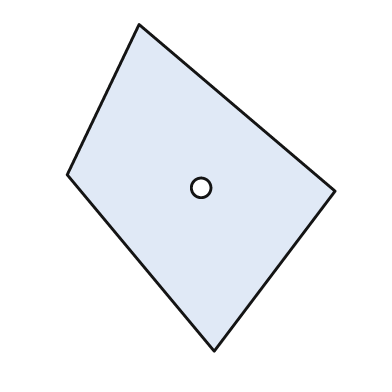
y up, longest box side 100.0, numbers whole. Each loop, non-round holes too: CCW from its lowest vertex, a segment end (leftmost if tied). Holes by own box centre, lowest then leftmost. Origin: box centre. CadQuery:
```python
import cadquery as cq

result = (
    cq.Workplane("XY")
    .moveTo(4.0, -50.0)
    .lineTo(41.0, -1.0)
    .lineTo(-19.0, 50.0)
    .lineTo(-41.0, 4.0)
    .close()
    .moveTo(0.0, 0.0)
    .circle(3.0)
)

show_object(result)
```